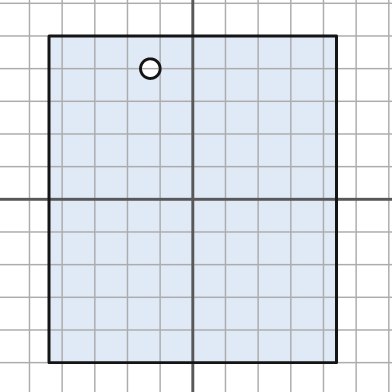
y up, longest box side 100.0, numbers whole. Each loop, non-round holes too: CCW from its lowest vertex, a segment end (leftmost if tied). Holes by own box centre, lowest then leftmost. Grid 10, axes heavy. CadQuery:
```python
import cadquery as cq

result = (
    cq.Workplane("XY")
    .moveTo(-44.0, -50.0)
    .lineTo(44.0, -50.0)
    .lineTo(44.0, 50.0)
    .lineTo(-44.0, 50.0)
    .close()
    .moveTo(-13.0, 40.0)
    .circle(3.0)
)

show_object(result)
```